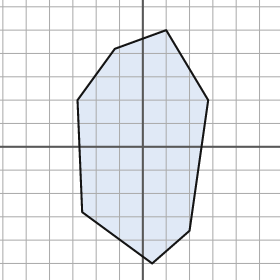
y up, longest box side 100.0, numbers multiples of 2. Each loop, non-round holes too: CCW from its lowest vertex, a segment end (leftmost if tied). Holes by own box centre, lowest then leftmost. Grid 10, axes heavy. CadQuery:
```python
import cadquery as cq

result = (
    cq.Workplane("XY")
    .moveTo(4.0, -50.0)
    .lineTo(20.0, -36.0)
    .lineTo(28.0, 20.0)
    .lineTo(10.0, 50.0)
    .lineTo(-12.0, 42.0)
    .lineTo(-28.0, 20.0)
    .lineTo(-26.0, -28.0)
    .close()
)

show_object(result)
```